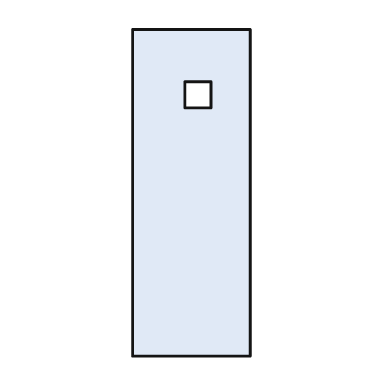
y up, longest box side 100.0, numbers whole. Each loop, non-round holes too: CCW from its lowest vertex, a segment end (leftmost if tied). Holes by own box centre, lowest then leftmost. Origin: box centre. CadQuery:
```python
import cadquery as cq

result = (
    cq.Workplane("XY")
    .moveTo(-18.0, -50.0)
    .lineTo(18.0, -50.0)
    .lineTo(18.0, 50.0)
    .lineTo(-18.0, 50.0)
    .close()
    .moveTo(-2.0, 26.0)
    .lineTo(6.0, 26.0)
    .lineTo(6.0, 34.0)
    .lineTo(-2.0, 34.0)
    .close()
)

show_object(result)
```